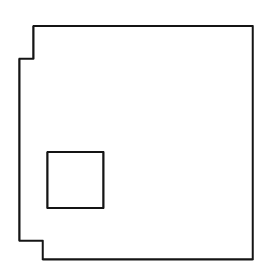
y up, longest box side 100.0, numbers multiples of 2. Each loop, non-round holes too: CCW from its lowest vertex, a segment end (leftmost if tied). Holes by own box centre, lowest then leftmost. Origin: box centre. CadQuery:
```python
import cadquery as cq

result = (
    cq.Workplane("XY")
    .moveTo(-40.0, -50.0)
    .lineTo(50.0, -50.0)
    .lineTo(50.0, 50.0)
    .lineTo(-44.0, 50.0)
    .lineTo(-44.0, 36.0)
    .lineTo(-50.0, 36.0)
    .lineTo(-50.0, -42.0)
    .lineTo(-40.0, -42.0)
    .close()
    .moveTo(-38.0, -28.0)
    .lineTo(-14.0, -28.0)
    .lineTo(-14.0, -4.0)
    .lineTo(-38.0, -4.0)
    .close()
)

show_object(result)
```